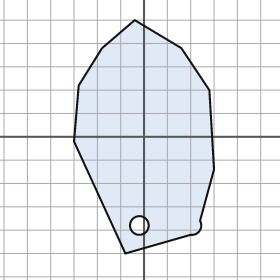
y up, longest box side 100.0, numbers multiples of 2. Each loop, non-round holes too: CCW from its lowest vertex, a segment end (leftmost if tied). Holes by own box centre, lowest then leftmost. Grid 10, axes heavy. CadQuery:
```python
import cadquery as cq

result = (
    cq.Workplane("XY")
    .moveTo(-8.0, -50.0)
    .lineTo(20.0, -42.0)
    .threePointArc((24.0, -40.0), (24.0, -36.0))
    .lineTo(30.0, -14.0)
    .lineTo(28.0, 20.0)
    .lineTo(16.0, 38.0)
    .lineTo(-4.0, 50.0)
    .lineTo(-18.0, 38.0)
    .lineTo(-28.0, 22.0)
    .lineTo(-30.0, -2.0)
    .close()
    .moveTo(-2.0, -38.0)
    .circle(4.0)
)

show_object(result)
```